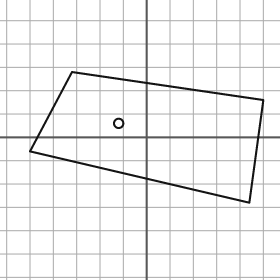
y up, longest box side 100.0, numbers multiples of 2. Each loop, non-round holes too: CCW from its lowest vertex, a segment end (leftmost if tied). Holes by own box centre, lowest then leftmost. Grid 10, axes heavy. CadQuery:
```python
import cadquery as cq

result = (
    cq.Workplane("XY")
    .moveTo(44.0, -28.0)
    .lineTo(50.0, 16.0)
    .lineTo(-32.0, 28.0)
    .lineTo(-50.0, -6.0)
    .close()
    .moveTo(-12.0, 6.0)
    .circle(2.0)
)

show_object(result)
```